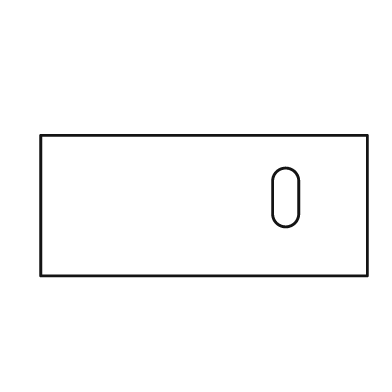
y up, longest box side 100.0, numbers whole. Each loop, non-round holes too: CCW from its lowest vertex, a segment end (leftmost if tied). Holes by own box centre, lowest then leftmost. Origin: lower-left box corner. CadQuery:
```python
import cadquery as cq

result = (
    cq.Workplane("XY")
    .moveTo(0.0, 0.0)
    .lineTo(100.0, 0.0)
    .lineTo(100.0, 43.0)
    .lineTo(0.0, 43.0)
    .close()
    .moveTo(71.0, 19.0)
    .threePointArc((75.0, 15.0), (79.0, 19.0))
    .lineTo(79.0, 29.0)
    .threePointArc((75.0, 33.0), (71.0, 29.0))
    .close()
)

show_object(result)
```